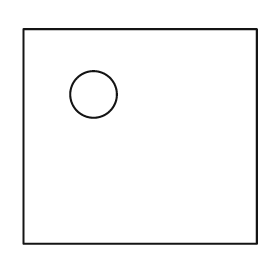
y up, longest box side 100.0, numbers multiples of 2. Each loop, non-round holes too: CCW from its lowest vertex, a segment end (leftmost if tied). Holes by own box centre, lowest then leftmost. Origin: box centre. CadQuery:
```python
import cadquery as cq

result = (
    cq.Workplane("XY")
    .moveTo(-50.0, -46.0)
    .lineTo(50.0, -46.0)
    .lineTo(50.0, 46.0)
    .lineTo(-50.0, 46.0)
    .close()
    .moveTo(-20.0, 18.0)
    .circle(10.0)
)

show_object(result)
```